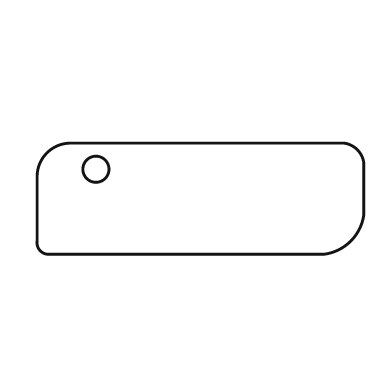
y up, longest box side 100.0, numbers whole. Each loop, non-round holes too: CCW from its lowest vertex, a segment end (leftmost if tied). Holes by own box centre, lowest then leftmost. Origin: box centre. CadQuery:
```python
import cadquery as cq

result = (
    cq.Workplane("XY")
    .moveTo(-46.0, -17.0)
    .lineTo(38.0, -17.0)
    .threePointArc((46.0, -13.0), (50.0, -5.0))
    .lineTo(50.0, 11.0)
    .threePointArc((48.0, 15.0), (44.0, 17.0))
    .lineTo(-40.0, 17.0)
    .threePointArc((-47.0, 14.0), (-50.0, 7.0))
    .lineTo(-50.0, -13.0)
    .threePointArc((-49.0, -16.0), (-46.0, -17.0))
    .close()
    .moveTo(-32.0, 9.0)
    .circle(4.0)
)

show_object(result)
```